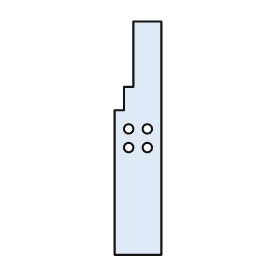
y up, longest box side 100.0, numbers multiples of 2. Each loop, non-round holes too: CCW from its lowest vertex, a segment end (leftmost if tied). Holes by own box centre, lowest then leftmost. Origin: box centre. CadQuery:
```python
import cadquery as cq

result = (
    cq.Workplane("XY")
    .moveTo(-10.0, -50.0)
    .lineTo(10.0, -50.0)
    .lineTo(10.0, 50.0)
    .lineTo(-2.0, 50.0)
    .lineTo(-2.0, 22.0)
    .lineTo(-6.0, 22.0)
    .lineTo(-6.0, 12.0)
    .lineTo(-10.0, 12.0)
    .close()
    .moveTo(-4.0, -4.0)
    .circle(2.0)
    .moveTo(4.0, -4.0)
    .circle(2.0)
    .moveTo(-4.0, 4.0)
    .circle(2.0)
    .moveTo(4.0, 4.0)
    .circle(2.0)
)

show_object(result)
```